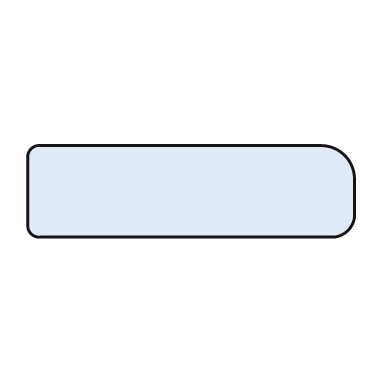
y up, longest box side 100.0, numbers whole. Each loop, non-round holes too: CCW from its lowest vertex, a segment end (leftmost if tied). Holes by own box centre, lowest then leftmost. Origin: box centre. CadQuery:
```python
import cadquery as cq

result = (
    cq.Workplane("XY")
    .moveTo(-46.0, -14.0)
    .lineTo(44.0, -14.0)
    .threePointArc((48.0, -12.0), (50.0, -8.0))
    .lineTo(50.0, 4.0)
    .threePointArc((47.0, 11.0), (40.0, 14.0))
    .lineTo(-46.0, 14.0)
    .threePointArc((-49.0, 13.0), (-50.0, 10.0))
    .lineTo(-50.0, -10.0)
    .threePointArc((-49.0, -13.0), (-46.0, -14.0))
    .close()
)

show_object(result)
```